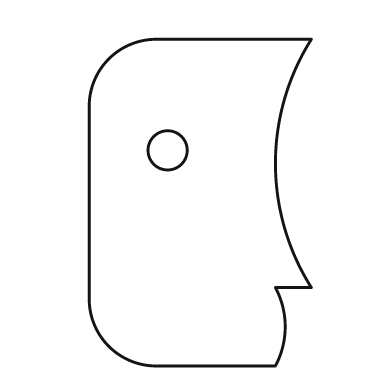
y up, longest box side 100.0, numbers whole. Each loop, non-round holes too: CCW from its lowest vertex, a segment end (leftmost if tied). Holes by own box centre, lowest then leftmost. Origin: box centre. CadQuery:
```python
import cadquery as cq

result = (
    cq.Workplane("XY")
    .moveTo(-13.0, -50.0)
    .lineTo(23.0, -50.0)
    .threePointArc((26.0, -38.0), (23.0, -26.0))
    .lineTo(34.0, -26.0)
    .threePointArc((23.0, 12.0), (34.0, 50.0))
    .lineTo(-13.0, 50.0)
    .threePointArc((-28.0, 44.0), (-34.0, 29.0))
    .lineTo(-34.0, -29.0)
    .threePointArc((-28.0, -44.0), (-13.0, -50.0))
    .close()
    .moveTo(-10.0, 16.0)
    .circle(6.0)
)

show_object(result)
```